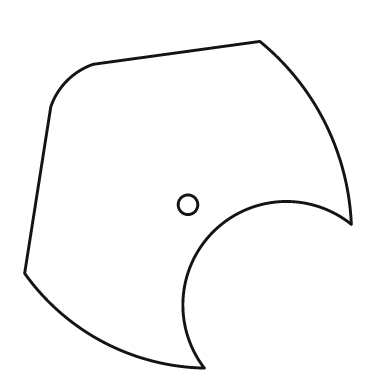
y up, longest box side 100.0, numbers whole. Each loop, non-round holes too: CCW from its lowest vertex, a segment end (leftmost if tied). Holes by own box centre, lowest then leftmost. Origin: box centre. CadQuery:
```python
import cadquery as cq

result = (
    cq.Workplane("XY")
    .moveTo(5.0, -50.0)
    .threePointArc((8.0, -8.0), (50.0, -6.0))
    .threePointArc((42.0, 25.0), (22.0, 50.0))
    .lineTo(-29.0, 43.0)
    .threePointArc((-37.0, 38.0), (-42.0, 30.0))
    .lineTo(-50.0, -21.0)
    .threePointArc((-26.0, -42.0), (5.0, -50.0))
    .close()
    .moveTo(0.0, 0.0)
    .circle(3.0)
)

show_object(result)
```